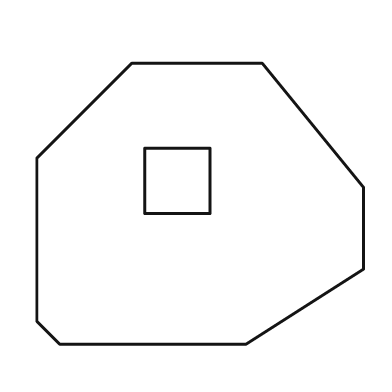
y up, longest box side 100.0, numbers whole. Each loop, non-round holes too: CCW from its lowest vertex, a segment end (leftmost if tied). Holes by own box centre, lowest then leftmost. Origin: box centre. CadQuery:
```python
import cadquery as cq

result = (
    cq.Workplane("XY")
    .moveTo(-43.0, -43.0)
    .lineTo(14.0, -43.0)
    .lineTo(50.0, -20.0)
    .lineTo(50.0, 5.0)
    .lineTo(19.0, 43.0)
    .lineTo(-21.0, 43.0)
    .lineTo(-50.0, 14.0)
    .lineTo(-50.0, -36.0)
    .close()
    .moveTo(-17.0, -3.0)
    .lineTo(3.0, -3.0)
    .lineTo(3.0, 17.0)
    .lineTo(-17.0, 17.0)
    .close()
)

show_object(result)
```